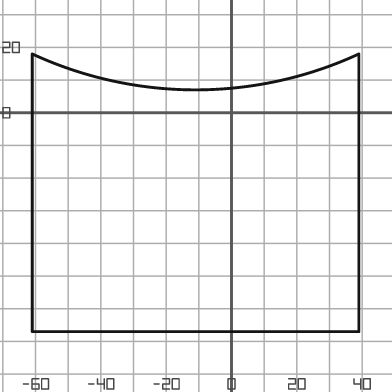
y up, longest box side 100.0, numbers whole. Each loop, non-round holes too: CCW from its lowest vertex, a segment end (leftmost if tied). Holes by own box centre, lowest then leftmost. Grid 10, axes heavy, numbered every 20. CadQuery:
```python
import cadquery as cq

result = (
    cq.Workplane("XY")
    .moveTo(-61.0, -67.0)
    .lineTo(39.0, -67.0)
    .lineTo(39.0, 18.0)
    .threePointArc((-11.0, 7.0), (-61.0, 18.0))
    .close()
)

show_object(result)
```